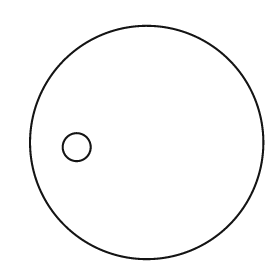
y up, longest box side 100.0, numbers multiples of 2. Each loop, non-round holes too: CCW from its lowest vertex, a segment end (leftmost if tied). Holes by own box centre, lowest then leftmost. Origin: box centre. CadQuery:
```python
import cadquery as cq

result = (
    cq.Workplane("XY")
    .moveTo(0.0, 0.0)
    .circle(50.0)
    .moveTo(-30.0, -2.0)
    .circle(6.0)
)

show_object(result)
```